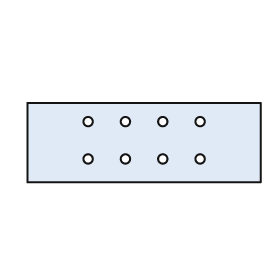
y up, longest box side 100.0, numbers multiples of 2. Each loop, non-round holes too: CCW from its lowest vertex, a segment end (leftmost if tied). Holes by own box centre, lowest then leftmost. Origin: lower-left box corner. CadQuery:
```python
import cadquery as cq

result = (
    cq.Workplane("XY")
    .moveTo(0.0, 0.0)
    .lineTo(100.0, 0.0)
    .lineTo(100.0, 34.0)
    .lineTo(0.0, 34.0)
    .close()
    .moveTo(26.0, 10.0)
    .circle(2.0)
    .moveTo(42.0, 10.0)
    .circle(2.0)
    .moveTo(58.0, 10.0)
    .circle(2.0)
    .moveTo(74.0, 10.0)
    .circle(2.0)
    .moveTo(26.0, 26.0)
    .circle(2.0)
    .moveTo(42.0, 26.0)
    .circle(2.0)
    .moveTo(58.0, 26.0)
    .circle(2.0)
    .moveTo(74.0, 26.0)
    .circle(2.0)
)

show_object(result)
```